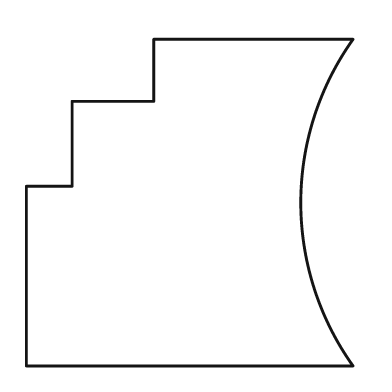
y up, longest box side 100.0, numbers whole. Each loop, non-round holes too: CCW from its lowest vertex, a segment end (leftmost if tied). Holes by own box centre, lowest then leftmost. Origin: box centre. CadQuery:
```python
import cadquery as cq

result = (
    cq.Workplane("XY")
    .moveTo(-50.0, -50.0)
    .lineTo(50.0, -50.0)
    .threePointArc((34.0, 0.0), (50.0, 50.0))
    .lineTo(-11.0, 50.0)
    .lineTo(-11.0, 31.0)
    .lineTo(-36.0, 31.0)
    .lineTo(-36.0, 5.0)
    .lineTo(-50.0, 5.0)
    .close()
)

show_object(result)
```